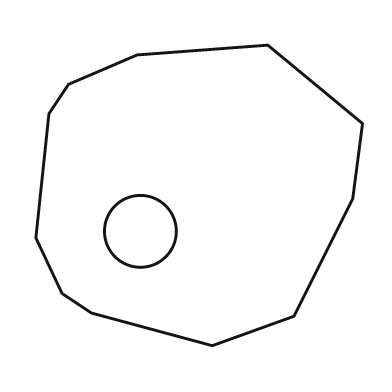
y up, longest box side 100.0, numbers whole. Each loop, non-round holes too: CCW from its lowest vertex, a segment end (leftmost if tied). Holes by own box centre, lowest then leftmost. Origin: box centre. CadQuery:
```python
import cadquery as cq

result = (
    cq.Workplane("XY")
    .moveTo(4.0, -46.0)
    .lineTo(29.0, -37.0)
    .lineTo(47.0, -1.0)
    .lineTo(50.0, 22.0)
    .lineTo(21.0, 46.0)
    .lineTo(-19.0, 43.0)
    .lineTo(-40.0, 34.0)
    .lineTo(-46.0, 25.0)
    .lineTo(-50.0, -13.0)
    .lineTo(-42.0, -30.0)
    .lineTo(-33.0, -36.0)
    .close()
    .moveTo(-18.0, -11.0)
    .circle(11.0)
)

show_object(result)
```